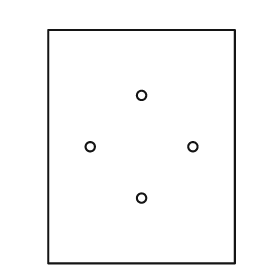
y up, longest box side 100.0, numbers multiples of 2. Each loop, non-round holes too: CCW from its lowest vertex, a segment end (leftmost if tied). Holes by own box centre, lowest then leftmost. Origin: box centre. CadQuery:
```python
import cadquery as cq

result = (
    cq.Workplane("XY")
    .moveTo(-40.0, -50.0)
    .lineTo(40.0, -50.0)
    .lineTo(40.0, 50.0)
    .lineTo(-40.0, 50.0)
    .close()
    .moveTo(0.0, -22.0)
    .circle(2.0)
    .moveTo(-22.0, 0.0)
    .circle(2.0)
    .moveTo(22.0, 0.0)
    .circle(2.0)
    .moveTo(0.0, 22.0)
    .circle(2.0)
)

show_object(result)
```